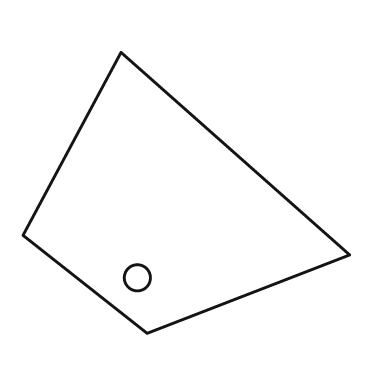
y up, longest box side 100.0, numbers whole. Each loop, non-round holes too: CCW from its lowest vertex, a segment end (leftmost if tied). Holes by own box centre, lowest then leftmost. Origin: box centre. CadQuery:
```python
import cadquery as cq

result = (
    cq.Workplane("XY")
    .moveTo(-12.0, -43.0)
    .lineTo(50.0, -19.0)
    .lineTo(-20.0, 43.0)
    .lineTo(-50.0, -13.0)
    .close()
    .moveTo(-15.0, -26.0)
    .circle(4.0)
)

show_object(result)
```